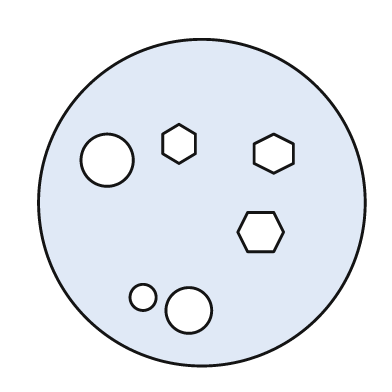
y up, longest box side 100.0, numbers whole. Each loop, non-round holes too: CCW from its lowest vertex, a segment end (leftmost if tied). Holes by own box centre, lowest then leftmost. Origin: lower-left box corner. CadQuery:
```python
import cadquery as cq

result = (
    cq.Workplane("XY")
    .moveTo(50.0, 50.0)
    .circle(50.0)
    .moveTo(46.0, 17.0)
    .circle(7.0)
    .moveTo(32.0, 21.0)
    .circle(4.0)
    .moveTo(64.0, 35.0)
    .lineTo(72.0, 35.0)
    .lineTo(75.0, 41.0)
    .lineTo(72.0, 47.0)
    .lineTo(64.0, 47.0)
    .lineTo(61.0, 41.0)
    .close()
    .moveTo(21.0, 63.0)
    .circle(8.0)
    .moveTo(72.0, 59.0)
    .lineTo(78.0, 62.0)
    .lineTo(78.0, 68.0)
    .lineTo(72.0, 71.0)
    .lineTo(66.0, 68.0)
    .lineTo(66.0, 62.0)
    .close()
    .moveTo(43.0, 62.0)
    .lineTo(48.0, 65.0)
    .lineTo(48.0, 71.0)
    .lineTo(43.0, 74.0)
    .lineTo(38.0, 71.0)
    .lineTo(38.0, 65.0)
    .close()
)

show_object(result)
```